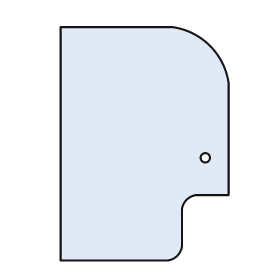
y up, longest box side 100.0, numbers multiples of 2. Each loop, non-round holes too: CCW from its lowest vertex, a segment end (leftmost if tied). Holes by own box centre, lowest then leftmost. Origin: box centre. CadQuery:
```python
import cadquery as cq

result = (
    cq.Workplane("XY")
    .moveTo(-36.0, -50.0)
    .lineTo(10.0, -50.0)
    .threePointArc((14.0, -48.0), (16.0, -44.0))
    .lineTo(16.0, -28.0)
    .threePointArc((18.0, -24.0), (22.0, -22.0))
    .lineTo(36.0, -22.0)
    .lineTo(36.0, 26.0)
    .threePointArc((28.0, 42.0), (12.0, 50.0))
    .lineTo(-36.0, 50.0)
    .close()
    .moveTo(26.0, -6.0)
    .circle(2.0)
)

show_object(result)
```